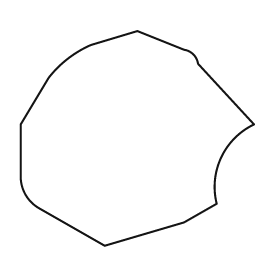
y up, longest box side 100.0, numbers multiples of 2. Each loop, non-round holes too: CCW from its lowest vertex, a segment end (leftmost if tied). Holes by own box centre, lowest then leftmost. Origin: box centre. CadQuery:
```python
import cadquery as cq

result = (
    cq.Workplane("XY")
    .moveTo(-14.0, -46.0)
    .lineTo(20.0, -36.0)
    .lineTo(34.0, -28.0)
    .threePointArc((36.0, -8.0), (50.0, 6.0))
    .lineTo(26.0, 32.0)
    .threePointArc((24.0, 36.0), (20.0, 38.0))
    .lineTo(0.0, 46.0)
    .lineTo(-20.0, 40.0)
    .threePointArc((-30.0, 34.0), (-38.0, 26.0))
    .lineTo(-50.0, 6.0)
    .lineTo(-50.0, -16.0)
    .threePointArc((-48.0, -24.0), (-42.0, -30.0))
    .close()
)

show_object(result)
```